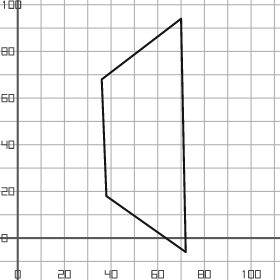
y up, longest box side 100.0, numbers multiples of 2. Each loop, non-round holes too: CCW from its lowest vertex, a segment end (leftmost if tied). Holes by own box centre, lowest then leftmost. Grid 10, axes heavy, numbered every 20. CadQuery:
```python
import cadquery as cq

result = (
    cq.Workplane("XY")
    .moveTo(72.0, -6.0)
    .lineTo(70.0, 94.0)
    .lineTo(36.0, 68.0)
    .lineTo(38.0, 18.0)
    .close()
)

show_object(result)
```